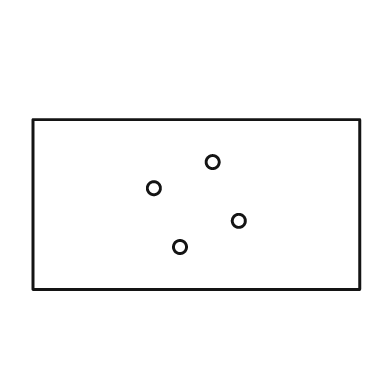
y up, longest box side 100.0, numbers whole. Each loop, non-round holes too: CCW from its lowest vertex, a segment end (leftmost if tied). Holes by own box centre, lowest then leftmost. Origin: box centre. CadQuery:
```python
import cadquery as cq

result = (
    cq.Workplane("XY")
    .moveTo(-50.0, -26.0)
    .lineTo(50.0, -26.0)
    .lineTo(50.0, 26.0)
    .lineTo(-50.0, 26.0)
    .close()
    .moveTo(-5.0, -13.0)
    .circle(2.0)
    .moveTo(13.0, -5.0)
    .circle(2.0)
    .moveTo(-13.0, 5.0)
    .circle(2.0)
    .moveTo(5.0, 13.0)
    .circle(2.0)
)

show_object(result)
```